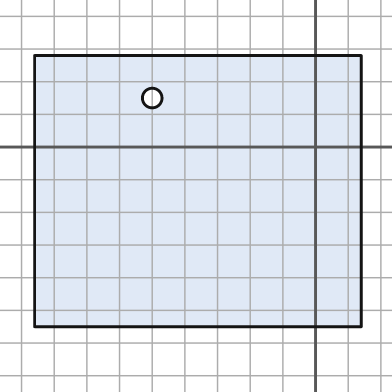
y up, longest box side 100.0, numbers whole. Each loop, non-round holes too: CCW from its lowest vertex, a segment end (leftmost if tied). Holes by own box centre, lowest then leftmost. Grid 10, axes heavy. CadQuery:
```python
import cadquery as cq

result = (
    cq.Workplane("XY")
    .moveTo(-86.0, -55.0)
    .lineTo(14.0, -55.0)
    .lineTo(14.0, 28.0)
    .lineTo(-86.0, 28.0)
    .close()
    .moveTo(-50.0, 15.0)
    .circle(3.0)
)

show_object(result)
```